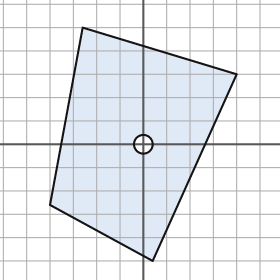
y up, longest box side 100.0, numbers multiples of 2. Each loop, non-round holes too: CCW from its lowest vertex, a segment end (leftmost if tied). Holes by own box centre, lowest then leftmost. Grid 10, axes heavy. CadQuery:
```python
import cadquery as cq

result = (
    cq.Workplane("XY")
    .moveTo(4.0, -50.0)
    .lineTo(40.0, 30.0)
    .lineTo(-26.0, 50.0)
    .lineTo(-40.0, -26.0)
    .close()
    .moveTo(0.0, 0.0)
    .circle(4.0)
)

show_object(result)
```